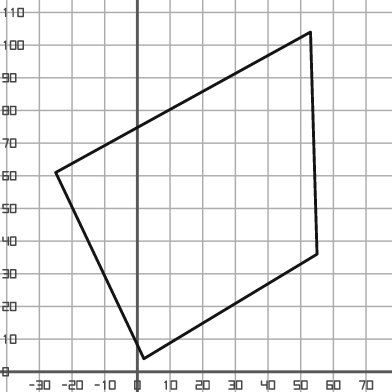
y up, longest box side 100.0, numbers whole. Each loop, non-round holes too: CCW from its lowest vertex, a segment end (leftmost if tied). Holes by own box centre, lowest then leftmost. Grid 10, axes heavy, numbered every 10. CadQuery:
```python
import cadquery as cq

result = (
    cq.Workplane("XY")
    .moveTo(2.0, 4.0)
    .lineTo(55.0, 36.0)
    .lineTo(53.0, 104.0)
    .lineTo(-25.0, 61.0)
    .close()
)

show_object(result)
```